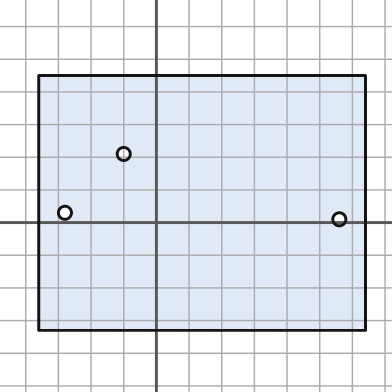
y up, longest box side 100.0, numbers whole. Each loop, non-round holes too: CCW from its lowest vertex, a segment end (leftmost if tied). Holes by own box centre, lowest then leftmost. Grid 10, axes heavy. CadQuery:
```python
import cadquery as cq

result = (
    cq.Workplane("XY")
    .moveTo(-36.0, -33.0)
    .lineTo(64.0, -33.0)
    .lineTo(64.0, 45.0)
    .lineTo(-36.0, 45.0)
    .close()
    .moveTo(56.0, 1.0)
    .circle(2.0)
    .moveTo(-28.0, 3.0)
    .circle(2.0)
    .moveTo(-10.0, 21.0)
    .circle(2.0)
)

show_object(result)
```